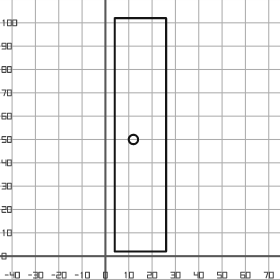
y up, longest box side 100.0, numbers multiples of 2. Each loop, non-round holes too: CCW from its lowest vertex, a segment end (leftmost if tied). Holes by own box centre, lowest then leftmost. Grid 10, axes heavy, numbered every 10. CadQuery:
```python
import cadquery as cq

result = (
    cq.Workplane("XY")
    .moveTo(4.0, 2.0)
    .lineTo(26.0, 2.0)
    .lineTo(26.0, 102.0)
    .lineTo(4.0, 102.0)
    .close()
    .moveTo(12.0, 50.0)
    .circle(2.0)
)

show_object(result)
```